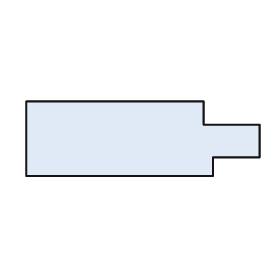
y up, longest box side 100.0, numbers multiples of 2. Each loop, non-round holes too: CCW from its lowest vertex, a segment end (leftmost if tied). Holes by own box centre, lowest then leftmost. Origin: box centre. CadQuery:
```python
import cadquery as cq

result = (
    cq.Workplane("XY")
    .moveTo(-50.0, -16.0)
    .lineTo(30.0, -16.0)
    .lineTo(30.0, -8.0)
    .lineTo(50.0, -8.0)
    .lineTo(50.0, 6.0)
    .lineTo(26.0, 6.0)
    .lineTo(26.0, 16.0)
    .lineTo(-50.0, 16.0)
    .close()
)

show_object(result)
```